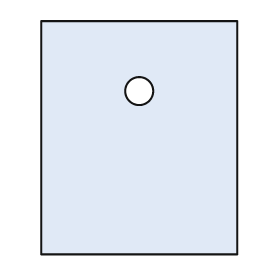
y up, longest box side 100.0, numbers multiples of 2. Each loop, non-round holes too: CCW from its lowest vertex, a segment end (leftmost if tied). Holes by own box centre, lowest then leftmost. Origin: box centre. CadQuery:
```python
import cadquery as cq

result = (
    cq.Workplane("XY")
    .moveTo(-42.0, -50.0)
    .lineTo(42.0, -50.0)
    .lineTo(42.0, 50.0)
    .lineTo(-42.0, 50.0)
    .close()
    .moveTo(0.0, 20.0)
    .circle(6.0)
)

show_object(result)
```